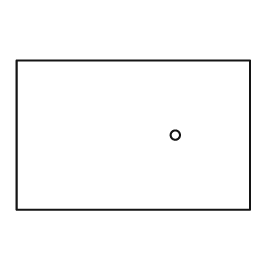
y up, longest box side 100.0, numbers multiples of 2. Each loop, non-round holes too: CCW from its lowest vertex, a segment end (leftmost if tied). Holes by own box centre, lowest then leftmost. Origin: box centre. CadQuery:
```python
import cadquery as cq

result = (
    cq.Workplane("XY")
    .moveTo(-50.0, -32.0)
    .lineTo(50.0, -32.0)
    .lineTo(50.0, 32.0)
    .lineTo(-50.0, 32.0)
    .close()
    .moveTo(18.0, 0.0)
    .circle(2.0)
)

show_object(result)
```